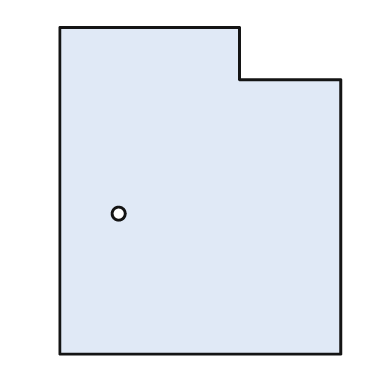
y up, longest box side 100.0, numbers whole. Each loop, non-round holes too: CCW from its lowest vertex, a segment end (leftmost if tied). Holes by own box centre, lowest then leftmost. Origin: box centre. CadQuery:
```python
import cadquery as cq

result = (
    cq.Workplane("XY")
    .moveTo(-43.0, -50.0)
    .lineTo(43.0, -50.0)
    .lineTo(43.0, 34.0)
    .lineTo(12.0, 34.0)
    .lineTo(12.0, 50.0)
    .lineTo(-43.0, 50.0)
    .close()
    .moveTo(-25.0, -7.0)
    .circle(2.0)
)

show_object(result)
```